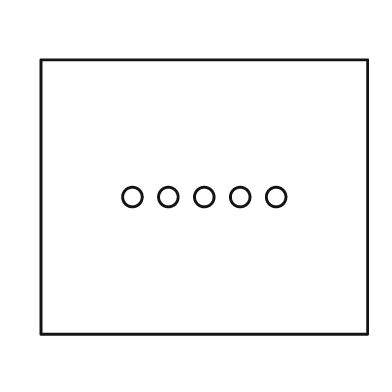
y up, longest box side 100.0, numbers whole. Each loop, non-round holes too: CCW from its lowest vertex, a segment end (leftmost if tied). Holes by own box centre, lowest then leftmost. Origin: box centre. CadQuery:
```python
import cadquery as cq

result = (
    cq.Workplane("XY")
    .moveTo(-50.0, -42.0)
    .lineTo(50.0, -42.0)
    .lineTo(50.0, 42.0)
    .lineTo(-50.0, 42.0)
    .close()
    .moveTo(-22.0, 0.0)
    .circle(3.0)
    .moveTo(-11.0, 0.0)
    .circle(3.0)
    .moveTo(0.0, 0.0)
    .circle(3.0)
    .moveTo(11.0, 0.0)
    .circle(3.0)
    .moveTo(22.0, 0.0)
    .circle(3.0)
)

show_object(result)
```